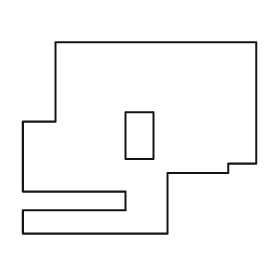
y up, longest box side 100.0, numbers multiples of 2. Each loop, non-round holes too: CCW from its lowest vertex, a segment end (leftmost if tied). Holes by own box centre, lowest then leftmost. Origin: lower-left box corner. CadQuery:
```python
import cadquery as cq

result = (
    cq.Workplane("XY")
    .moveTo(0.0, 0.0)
    .lineTo(62.0, 0.0)
    .lineTo(62.0, 26.0)
    .lineTo(88.0, 26.0)
    .lineTo(88.0, 30.0)
    .lineTo(100.0, 30.0)
    .lineTo(100.0, 82.0)
    .lineTo(14.0, 82.0)
    .lineTo(14.0, 48.0)
    .lineTo(0.0, 48.0)
    .lineTo(0.0, 18.0)
    .lineTo(44.0, 18.0)
    .lineTo(44.0, 10.0)
    .lineTo(0.0, 10.0)
    .close()
    .moveTo(44.0, 32.0)
    .lineTo(56.0, 32.0)
    .lineTo(56.0, 52.0)
    .lineTo(44.0, 52.0)
    .close()
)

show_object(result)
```